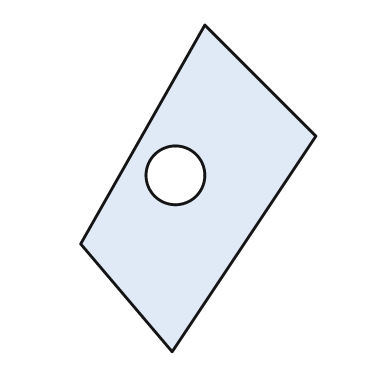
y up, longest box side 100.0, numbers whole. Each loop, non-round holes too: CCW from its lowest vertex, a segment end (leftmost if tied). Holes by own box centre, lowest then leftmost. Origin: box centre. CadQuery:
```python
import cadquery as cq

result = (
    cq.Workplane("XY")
    .moveTo(-8.0, -50.0)
    .lineTo(36.0, 16.0)
    .lineTo(2.0, 50.0)
    .lineTo(-36.0, -17.0)
    .close()
    .moveTo(-7.0, 4.0)
    .circle(9.0)
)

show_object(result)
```